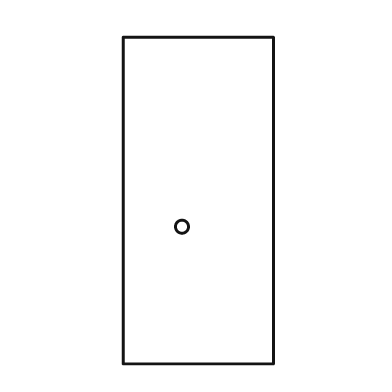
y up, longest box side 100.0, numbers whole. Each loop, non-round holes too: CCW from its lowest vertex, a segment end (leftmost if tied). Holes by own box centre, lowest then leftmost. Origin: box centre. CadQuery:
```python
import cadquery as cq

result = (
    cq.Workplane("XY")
    .moveTo(-23.0, -50.0)
    .lineTo(23.0, -50.0)
    .lineTo(23.0, 50.0)
    .lineTo(-23.0, 50.0)
    .close()
    .moveTo(-5.0, -8.0)
    .circle(2.0)
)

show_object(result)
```